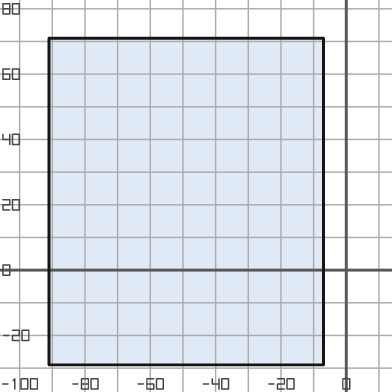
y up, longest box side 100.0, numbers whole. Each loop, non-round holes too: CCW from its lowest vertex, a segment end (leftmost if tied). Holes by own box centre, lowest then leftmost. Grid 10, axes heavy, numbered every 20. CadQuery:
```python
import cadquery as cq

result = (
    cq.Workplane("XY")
    .moveTo(-91.0, -29.0)
    .lineTo(-7.0, -29.0)
    .lineTo(-7.0, 71.0)
    .lineTo(-91.0, 71.0)
    .close()
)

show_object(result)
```